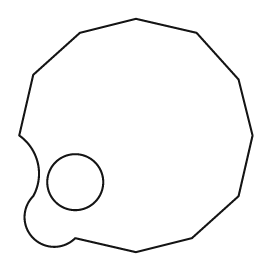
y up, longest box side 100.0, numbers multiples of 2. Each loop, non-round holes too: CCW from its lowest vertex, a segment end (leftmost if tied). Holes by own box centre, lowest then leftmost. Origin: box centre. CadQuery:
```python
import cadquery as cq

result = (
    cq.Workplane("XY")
    .moveTo(0.0, -50.0)
    .lineTo(24.0, -44.0)
    .lineTo(44.0, -26.0)
    .lineTo(50.0, 0.0)
    .lineTo(44.0, 24.0)
    .lineTo(26.0, 44.0)
    .lineTo(0.0, 50.0)
    .lineTo(-24.0, 44.0)
    .lineTo(-44.0, 26.0)
    .lineTo(-50.0, 0.0)
    .threePointArc((-42.0, -12.0), (-44.0, -26.0))
    .threePointArc((-44.0, -44.0), (-26.0, -44.0))
    .close()
    .moveTo(-26.0, -20.0)
    .circle(12.0)
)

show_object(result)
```